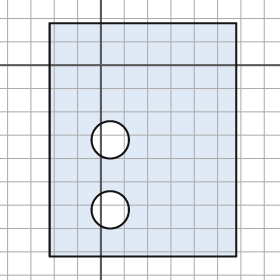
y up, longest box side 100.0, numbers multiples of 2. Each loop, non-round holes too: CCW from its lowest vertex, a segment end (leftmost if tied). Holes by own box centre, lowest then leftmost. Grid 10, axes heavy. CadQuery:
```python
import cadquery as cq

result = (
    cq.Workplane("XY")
    .moveTo(-22.0, -82.0)
    .lineTo(58.0, -82.0)
    .lineTo(58.0, 18.0)
    .lineTo(-22.0, 18.0)
    .close()
    .moveTo(4.0, -62.0)
    .circle(8.0)
    .moveTo(4.0, -32.0)
    .circle(8.0)
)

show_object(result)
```